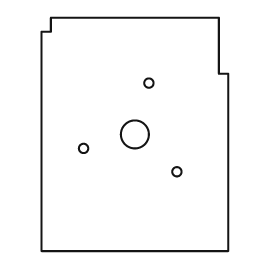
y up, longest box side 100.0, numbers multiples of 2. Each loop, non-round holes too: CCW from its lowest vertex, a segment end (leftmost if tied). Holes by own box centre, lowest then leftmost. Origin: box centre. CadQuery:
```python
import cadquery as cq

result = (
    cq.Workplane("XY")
    .moveTo(-40.0, -50.0)
    .lineTo(40.0, -50.0)
    .lineTo(40.0, 26.0)
    .lineTo(36.0, 26.0)
    .lineTo(36.0, 50.0)
    .lineTo(-36.0, 50.0)
    .lineTo(-36.0, 44.0)
    .lineTo(-40.0, 44.0)
    .close()
    .moveTo(18.0, -16.0)
    .circle(2.0)
    .moveTo(-22.0, -6.0)
    .circle(2.0)
    .moveTo(0.0, 0.0)
    .circle(6.0)
    .moveTo(6.0, 22.0)
    .circle(2.0)
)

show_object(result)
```